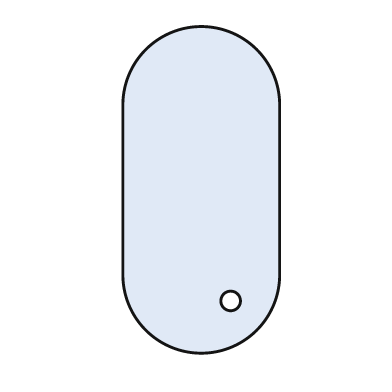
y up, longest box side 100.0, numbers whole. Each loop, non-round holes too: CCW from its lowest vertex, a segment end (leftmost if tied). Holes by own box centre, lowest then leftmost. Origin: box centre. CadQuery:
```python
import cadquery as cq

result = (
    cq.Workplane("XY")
    .moveTo(-24.0, -26.0)
    .threePointArc((0.0, -50.0), (24.0, -26.0))
    .lineTo(24.0, 26.0)
    .threePointArc((0.0, 50.0), (-24.0, 26.0))
    .close()
    .moveTo(9.0, -34.0)
    .circle(3.0)
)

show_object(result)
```